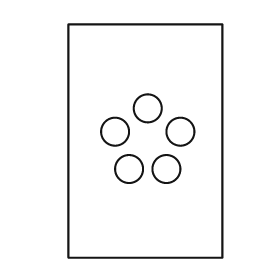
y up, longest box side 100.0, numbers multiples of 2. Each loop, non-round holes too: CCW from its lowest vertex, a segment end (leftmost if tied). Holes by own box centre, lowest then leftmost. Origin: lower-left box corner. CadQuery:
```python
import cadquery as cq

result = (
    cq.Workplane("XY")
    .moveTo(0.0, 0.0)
    .lineTo(66.0, 0.0)
    .lineTo(66.0, 100.0)
    .lineTo(0.0, 100.0)
    .close()
    .moveTo(26.0, 38.0)
    .circle(6.0)
    .moveTo(42.0, 38.0)
    .circle(6.0)
    .moveTo(20.0, 54.0)
    .circle(6.0)
    .moveTo(48.0, 54.0)
    .circle(6.0)
    .moveTo(34.0, 64.0)
    .circle(6.0)
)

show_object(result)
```